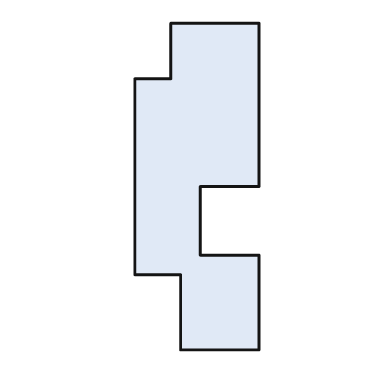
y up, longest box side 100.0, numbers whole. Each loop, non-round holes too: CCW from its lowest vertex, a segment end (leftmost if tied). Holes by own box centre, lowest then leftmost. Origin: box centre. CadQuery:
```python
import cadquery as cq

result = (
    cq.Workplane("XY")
    .moveTo(-5.0, -50.0)
    .lineTo(19.0, -50.0)
    .lineTo(19.0, -21.0)
    .lineTo(1.0, -21.0)
    .lineTo(1.0, 0.0)
    .lineTo(19.0, 0.0)
    .lineTo(19.0, 50.0)
    .lineTo(-8.0, 50.0)
    .lineTo(-8.0, 33.0)
    .lineTo(-19.0, 33.0)
    .lineTo(-19.0, -27.0)
    .lineTo(-5.0, -27.0)
    .close()
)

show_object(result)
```